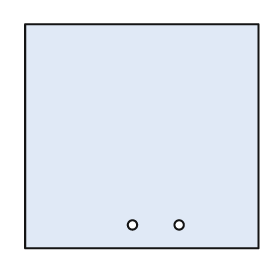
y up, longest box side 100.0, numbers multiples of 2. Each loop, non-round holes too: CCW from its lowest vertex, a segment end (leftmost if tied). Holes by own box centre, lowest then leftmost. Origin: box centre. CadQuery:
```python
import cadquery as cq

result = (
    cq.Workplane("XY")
    .moveTo(-50.0, -48.0)
    .lineTo(50.0, -48.0)
    .lineTo(50.0, 48.0)
    .lineTo(-50.0, 48.0)
    .close()
    .moveTo(-4.0, -38.0)
    .circle(2.0)
    .moveTo(16.0, -38.0)
    .circle(2.0)
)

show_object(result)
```